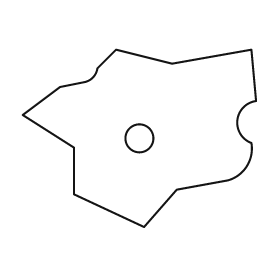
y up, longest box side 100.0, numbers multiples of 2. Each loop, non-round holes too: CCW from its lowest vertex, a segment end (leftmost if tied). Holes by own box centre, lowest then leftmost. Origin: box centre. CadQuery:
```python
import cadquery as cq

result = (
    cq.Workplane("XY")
    .moveTo(2.0, -38.0)
    .lineTo(16.0, -22.0)
    .lineTo(38.0, -18.0)
    .threePointArc((46.0, -12.0), (48.0, -2.0))
    .threePointArc((42.0, 8.0), (50.0, 16.0))
    .lineTo(48.0, 38.0)
    .lineTo(14.0, 32.0)
    .lineTo(-10.0, 38.0)
    .lineTo(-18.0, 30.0)
    .threePointArc((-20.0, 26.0), (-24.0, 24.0))
    .lineTo(-34.0, 22.0)
    .lineTo(-50.0, 10.0)
    .lineTo(-28.0, -4.0)
    .lineTo(-28.0, -24.0)
    .close()
    .moveTo(0.0, 0.0)
    .circle(6.0)
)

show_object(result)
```